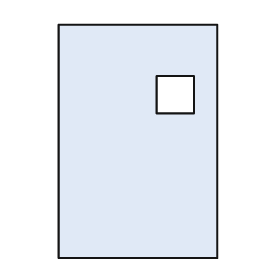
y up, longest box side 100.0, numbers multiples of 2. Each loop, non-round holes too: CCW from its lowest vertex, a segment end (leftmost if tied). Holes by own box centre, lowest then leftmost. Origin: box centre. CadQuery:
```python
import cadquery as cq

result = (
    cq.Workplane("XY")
    .moveTo(-34.0, -50.0)
    .lineTo(34.0, -50.0)
    .lineTo(34.0, 50.0)
    .lineTo(-34.0, 50.0)
    .close()
    .moveTo(8.0, 12.0)
    .lineTo(24.0, 12.0)
    .lineTo(24.0, 28.0)
    .lineTo(8.0, 28.0)
    .close()
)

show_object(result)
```